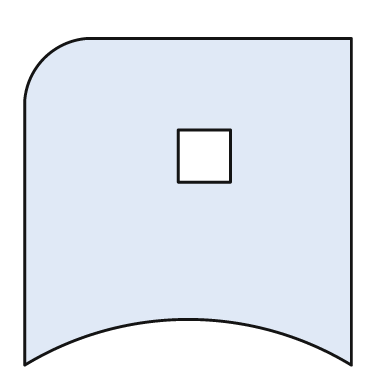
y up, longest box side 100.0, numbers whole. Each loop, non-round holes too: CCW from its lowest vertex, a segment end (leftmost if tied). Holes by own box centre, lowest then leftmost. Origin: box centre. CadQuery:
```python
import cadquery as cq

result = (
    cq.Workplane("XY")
    .moveTo(-50.0, -50.0)
    .threePointArc((0.0, -36.0), (50.0, -50.0))
    .lineTo(50.0, 50.0)
    .lineTo(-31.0, 50.0)
    .threePointArc((-44.0, 44.0), (-50.0, 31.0))
    .close()
    .moveTo(-3.0, 6.0)
    .lineTo(13.0, 6.0)
    .lineTo(13.0, 22.0)
    .lineTo(-3.0, 22.0)
    .close()
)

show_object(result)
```